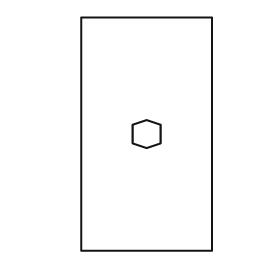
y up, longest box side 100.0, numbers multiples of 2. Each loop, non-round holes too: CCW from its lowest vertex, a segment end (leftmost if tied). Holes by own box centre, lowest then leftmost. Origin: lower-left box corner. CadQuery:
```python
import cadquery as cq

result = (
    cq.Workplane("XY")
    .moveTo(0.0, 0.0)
    .lineTo(56.0, 0.0)
    .lineTo(56.0, 100.0)
    .lineTo(0.0, 100.0)
    .close()
    .moveTo(28.0, 44.0)
    .lineTo(34.0, 46.0)
    .lineTo(34.0, 54.0)
    .lineTo(28.0, 56.0)
    .lineTo(22.0, 54.0)
    .lineTo(22.0, 46.0)
    .close()
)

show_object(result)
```